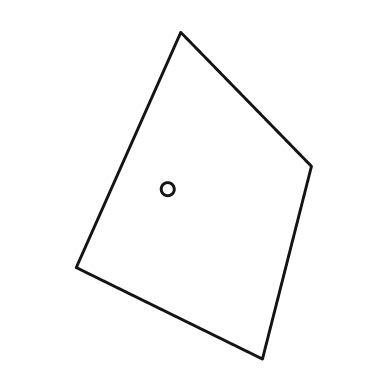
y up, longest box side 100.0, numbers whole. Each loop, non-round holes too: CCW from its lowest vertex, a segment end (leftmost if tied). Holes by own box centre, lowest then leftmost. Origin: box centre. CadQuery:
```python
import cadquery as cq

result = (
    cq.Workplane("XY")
    .moveTo(21.0, -50.0)
    .lineTo(36.0, 9.0)
    .lineTo(-4.0, 50.0)
    .lineTo(-36.0, -22.0)
    .close()
    .moveTo(-8.0, 2.0)
    .circle(2.0)
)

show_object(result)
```